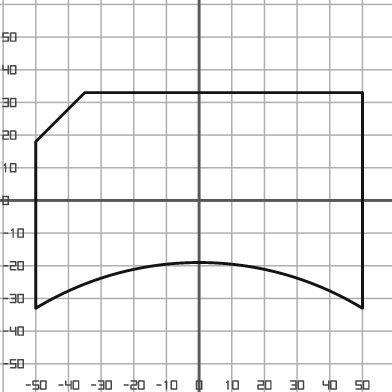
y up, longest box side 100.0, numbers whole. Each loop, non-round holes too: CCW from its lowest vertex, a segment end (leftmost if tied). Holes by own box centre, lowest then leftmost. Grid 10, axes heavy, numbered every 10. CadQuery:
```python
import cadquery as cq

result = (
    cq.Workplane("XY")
    .moveTo(-50.0, -33.0)
    .threePointArc((0.0, -19.0), (50.0, -33.0))
    .lineTo(50.0, 33.0)
    .lineTo(-35.0, 33.0)
    .lineTo(-50.0, 18.0)
    .close()
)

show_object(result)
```